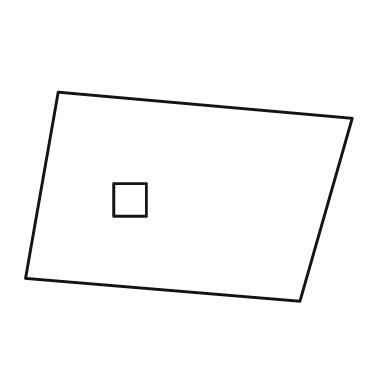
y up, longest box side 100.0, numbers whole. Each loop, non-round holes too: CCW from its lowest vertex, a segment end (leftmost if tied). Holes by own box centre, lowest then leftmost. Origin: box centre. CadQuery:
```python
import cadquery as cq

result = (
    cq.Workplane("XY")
    .moveTo(34.0, -32.0)
    .lineTo(50.0, 24.0)
    .lineTo(-40.0, 32.0)
    .lineTo(-50.0, -25.0)
    .close()
    .moveTo(-23.0, -6.0)
    .lineTo(-13.0, -6.0)
    .lineTo(-13.0, 4.0)
    .lineTo(-23.0, 4.0)
    .close()
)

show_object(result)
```